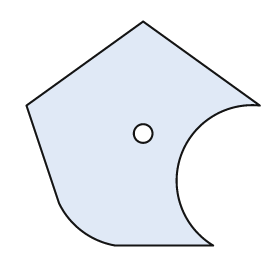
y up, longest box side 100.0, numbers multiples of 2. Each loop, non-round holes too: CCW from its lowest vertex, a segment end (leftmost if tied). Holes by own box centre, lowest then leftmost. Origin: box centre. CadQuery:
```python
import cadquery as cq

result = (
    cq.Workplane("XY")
    .moveTo(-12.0, -48.0)
    .lineTo(30.0, -48.0)
    .threePointArc((16.0, -10.0), (50.0, 12.0))
    .lineTo(0.0, 48.0)
    .lineTo(-50.0, 12.0)
    .lineTo(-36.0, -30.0)
    .threePointArc((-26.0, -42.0), (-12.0, -48.0))
    .close()
    .moveTo(0.0, 0.0)
    .circle(4.0)
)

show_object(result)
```